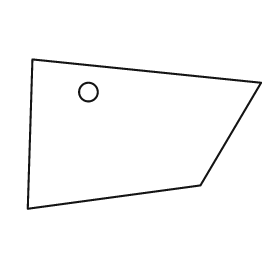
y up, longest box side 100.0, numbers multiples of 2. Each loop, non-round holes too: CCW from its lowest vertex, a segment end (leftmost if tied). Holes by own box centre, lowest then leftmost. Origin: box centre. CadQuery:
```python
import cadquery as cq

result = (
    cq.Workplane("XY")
    .moveTo(-50.0, -32.0)
    .lineTo(24.0, -22.0)
    .lineTo(50.0, 22.0)
    .lineTo(-48.0, 32.0)
    .close()
    .moveTo(-24.0, 18.0)
    .circle(4.0)
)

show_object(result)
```